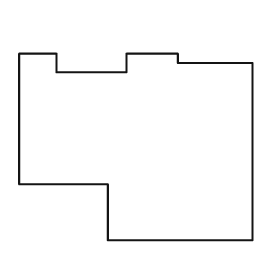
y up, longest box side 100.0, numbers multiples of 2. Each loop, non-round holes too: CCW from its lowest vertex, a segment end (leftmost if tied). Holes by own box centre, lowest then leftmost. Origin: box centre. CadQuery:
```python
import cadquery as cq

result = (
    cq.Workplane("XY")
    .moveTo(-12.0, -40.0)
    .lineTo(50.0, -40.0)
    .lineTo(50.0, 36.0)
    .lineTo(18.0, 36.0)
    .lineTo(18.0, 40.0)
    .lineTo(-4.0, 40.0)
    .lineTo(-4.0, 32.0)
    .lineTo(-34.0, 32.0)
    .lineTo(-34.0, 40.0)
    .lineTo(-50.0, 40.0)
    .lineTo(-50.0, -16.0)
    .lineTo(-12.0, -16.0)
    .close()
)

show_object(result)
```